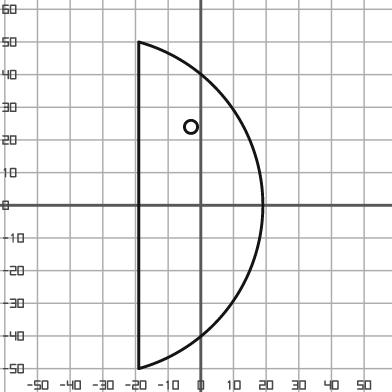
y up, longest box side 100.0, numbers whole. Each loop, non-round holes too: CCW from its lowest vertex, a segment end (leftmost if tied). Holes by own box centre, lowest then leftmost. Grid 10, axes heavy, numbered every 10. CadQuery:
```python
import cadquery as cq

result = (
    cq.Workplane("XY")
    .moveTo(-19.0, -50.0)
    .threePointArc((19.0, 0.0), (-19.0, 50.0))
    .close()
    .moveTo(-3.0, 24.0)
    .circle(2.0)
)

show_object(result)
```